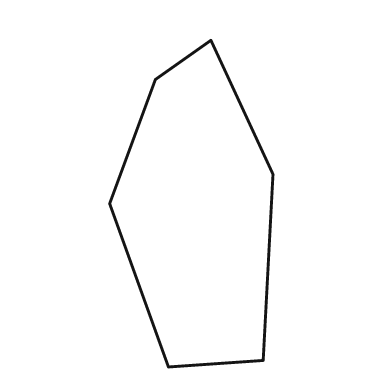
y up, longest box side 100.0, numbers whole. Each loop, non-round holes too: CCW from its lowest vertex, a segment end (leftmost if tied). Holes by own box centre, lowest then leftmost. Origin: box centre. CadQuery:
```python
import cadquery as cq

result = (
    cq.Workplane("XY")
    .moveTo(-7.0, -50.0)
    .lineTo(22.0, -48.0)
    .lineTo(25.0, 9.0)
    .lineTo(6.0, 50.0)
    .lineTo(-11.0, 38.0)
    .lineTo(-25.0, 0.0)
    .close()
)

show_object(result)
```